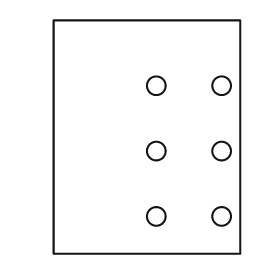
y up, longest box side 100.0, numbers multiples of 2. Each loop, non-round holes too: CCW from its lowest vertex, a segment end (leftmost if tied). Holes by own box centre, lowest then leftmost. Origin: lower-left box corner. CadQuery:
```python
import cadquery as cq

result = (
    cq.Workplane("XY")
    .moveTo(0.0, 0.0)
    .lineTo(80.0, 0.0)
    .lineTo(80.0, 100.0)
    .lineTo(0.0, 100.0)
    .close()
    .moveTo(44.0, 16.0)
    .circle(4.0)
    .moveTo(72.0, 16.0)
    .circle(4.0)
    .moveTo(44.0, 44.0)
    .circle(4.0)
    .moveTo(72.0, 44.0)
    .circle(4.0)
    .moveTo(44.0, 72.0)
    .circle(4.0)
    .moveTo(72.0, 72.0)
    .circle(4.0)
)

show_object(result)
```